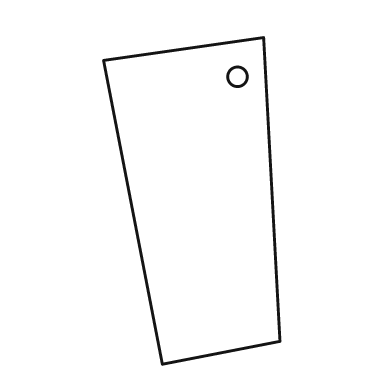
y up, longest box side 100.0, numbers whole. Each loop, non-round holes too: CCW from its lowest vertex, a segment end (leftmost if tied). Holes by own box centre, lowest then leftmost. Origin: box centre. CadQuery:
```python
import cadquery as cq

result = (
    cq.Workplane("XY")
    .moveTo(-9.0, -50.0)
    .lineTo(27.0, -43.0)
    .lineTo(22.0, 50.0)
    .lineTo(-27.0, 43.0)
    .close()
    .moveTo(14.0, 38.0)
    .circle(3.0)
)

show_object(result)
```